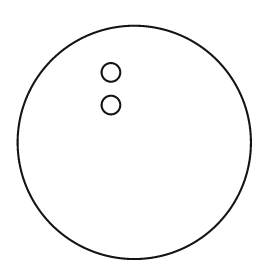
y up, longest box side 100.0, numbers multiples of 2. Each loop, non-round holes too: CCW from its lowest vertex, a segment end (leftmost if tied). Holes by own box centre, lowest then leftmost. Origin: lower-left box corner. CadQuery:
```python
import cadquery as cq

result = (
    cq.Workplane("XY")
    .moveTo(50.0, 50.0)
    .circle(50.0)
    .moveTo(40.0, 66.0)
    .circle(4.0)
    .moveTo(40.0, 80.0)
    .circle(4.0)
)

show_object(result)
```